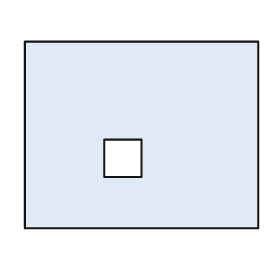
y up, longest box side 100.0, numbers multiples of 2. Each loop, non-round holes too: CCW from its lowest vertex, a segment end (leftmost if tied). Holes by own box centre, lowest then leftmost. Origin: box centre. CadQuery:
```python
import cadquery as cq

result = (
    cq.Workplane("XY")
    .moveTo(-50.0, -40.0)
    .lineTo(50.0, -40.0)
    .lineTo(50.0, 40.0)
    .lineTo(-50.0, 40.0)
    .close()
    .moveTo(-16.0, -18.0)
    .lineTo(0.0, -18.0)
    .lineTo(0.0, -2.0)
    .lineTo(-16.0, -2.0)
    .close()
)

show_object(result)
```